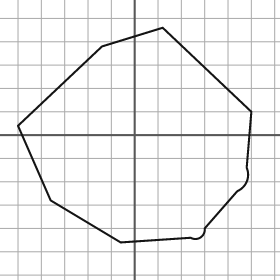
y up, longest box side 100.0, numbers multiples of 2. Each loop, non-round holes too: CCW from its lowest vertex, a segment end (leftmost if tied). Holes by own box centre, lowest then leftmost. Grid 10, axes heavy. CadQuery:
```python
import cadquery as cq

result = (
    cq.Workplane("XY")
    .moveTo(-6.0, -46.0)
    .lineTo(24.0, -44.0)
    .threePointArc((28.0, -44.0), (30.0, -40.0))
    .lineTo(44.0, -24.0)
    .threePointArc((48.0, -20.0), (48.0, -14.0))
    .lineTo(50.0, 10.0)
    .lineTo(12.0, 46.0)
    .lineTo(-14.0, 38.0)
    .lineTo(-50.0, 4.0)
    .lineTo(-36.0, -28.0)
    .close()
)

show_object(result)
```